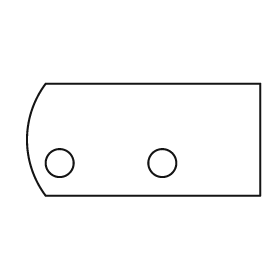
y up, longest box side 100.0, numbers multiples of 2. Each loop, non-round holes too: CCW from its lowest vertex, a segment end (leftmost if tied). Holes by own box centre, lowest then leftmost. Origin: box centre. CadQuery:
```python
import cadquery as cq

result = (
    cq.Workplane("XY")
    .moveTo(-42.0, -24.0)
    .lineTo(50.0, -24.0)
    .lineTo(50.0, 24.0)
    .lineTo(-42.0, 24.0)
    .threePointArc((-50.0, 0.0), (-42.0, -24.0))
    .close()
    .moveTo(-36.0, -10.0)
    .circle(6.0)
    .moveTo(8.0, -10.0)
    .circle(6.0)
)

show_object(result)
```